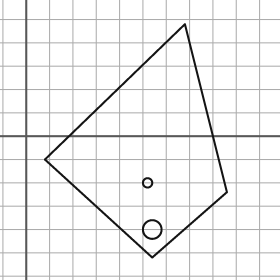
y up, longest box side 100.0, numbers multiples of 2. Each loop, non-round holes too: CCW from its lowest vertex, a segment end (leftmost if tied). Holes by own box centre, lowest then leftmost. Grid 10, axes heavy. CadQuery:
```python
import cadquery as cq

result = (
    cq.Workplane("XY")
    .moveTo(54.0, -52.0)
    .lineTo(86.0, -24.0)
    .lineTo(68.0, 48.0)
    .lineTo(8.0, -10.0)
    .close()
    .moveTo(54.0, -40.0)
    .circle(4.0)
    .moveTo(52.0, -20.0)
    .circle(2.0)
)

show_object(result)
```